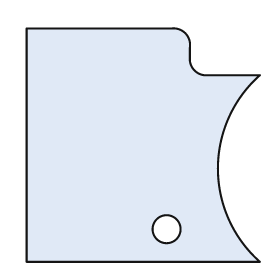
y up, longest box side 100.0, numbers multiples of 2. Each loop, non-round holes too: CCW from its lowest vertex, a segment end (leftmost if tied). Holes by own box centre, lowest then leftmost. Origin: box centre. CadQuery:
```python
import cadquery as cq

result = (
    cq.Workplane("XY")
    .moveTo(-50.0, -50.0)
    .lineTo(50.0, -50.0)
    .threePointArc((32.0, -10.0), (50.0, 30.0))
    .lineTo(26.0, 30.0)
    .threePointArc((22.0, 32.0), (20.0, 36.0))
    .lineTo(20.0, 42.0)
    .threePointArc((18.0, 48.0), (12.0, 50.0))
    .lineTo(-50.0, 50.0)
    .close()
    .moveTo(10.0, -36.0)
    .circle(6.0)
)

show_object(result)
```